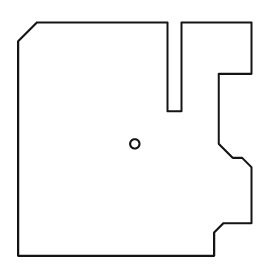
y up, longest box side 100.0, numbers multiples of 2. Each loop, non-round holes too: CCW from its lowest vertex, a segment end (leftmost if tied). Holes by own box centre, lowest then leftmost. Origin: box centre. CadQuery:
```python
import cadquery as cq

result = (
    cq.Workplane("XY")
    .moveTo(-50.0, -50.0)
    .lineTo(34.0, -50.0)
    .lineTo(34.0, -40.0)
    .lineTo(38.0, -36.0)
    .lineTo(50.0, -36.0)
    .lineTo(50.0, -12.0)
    .lineTo(46.0, -8.0)
    .lineTo(42.0, -8.0)
    .lineTo(36.0, -2.0)
    .lineTo(36.0, 28.0)
    .lineTo(50.0, 28.0)
    .lineTo(50.0, 50.0)
    .lineTo(20.0, 50.0)
    .lineTo(20.0, 12.0)
    .lineTo(14.0, 12.0)
    .lineTo(14.0, 50.0)
    .lineTo(-42.0, 50.0)
    .lineTo(-50.0, 42.0)
    .close()
    .moveTo(0.0, -2.0)
    .circle(2.0)
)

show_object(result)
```